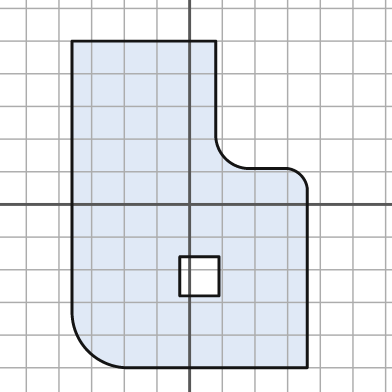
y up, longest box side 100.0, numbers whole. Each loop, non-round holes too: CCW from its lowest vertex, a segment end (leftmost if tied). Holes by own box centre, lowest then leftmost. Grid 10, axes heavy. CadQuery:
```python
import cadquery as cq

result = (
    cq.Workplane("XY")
    .moveTo(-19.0, -50.0)
    .lineTo(36.0, -50.0)
    .lineTo(36.0, 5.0)
    .threePointArc((34.0, 9.0), (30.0, 11.0))
    .lineTo(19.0, 11.0)
    .threePointArc((11.0, 14.0), (8.0, 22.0))
    .lineTo(8.0, 50.0)
    .lineTo(-36.0, 50.0)
    .lineTo(-36.0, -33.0)
    .threePointArc((-31.0, -45.0), (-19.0, -50.0))
    .close()
    .moveTo(-3.0, -28.0)
    .lineTo(9.0, -28.0)
    .lineTo(9.0, -16.0)
    .lineTo(-3.0, -16.0)
    .close()
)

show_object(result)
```